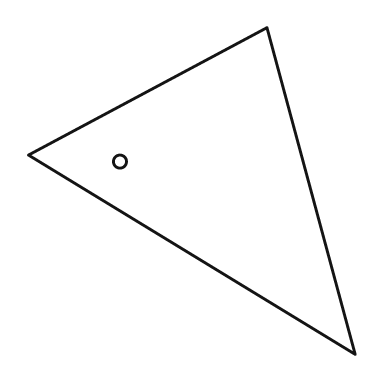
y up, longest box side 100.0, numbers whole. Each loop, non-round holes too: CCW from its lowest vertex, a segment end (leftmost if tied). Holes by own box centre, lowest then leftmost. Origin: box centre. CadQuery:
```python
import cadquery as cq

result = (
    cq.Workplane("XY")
    .moveTo(50.0, -50.0)
    .lineTo(23.0, 50.0)
    .lineTo(-50.0, 11.0)
    .close()
    .moveTo(-22.0, 9.0)
    .circle(2.0)
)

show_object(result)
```